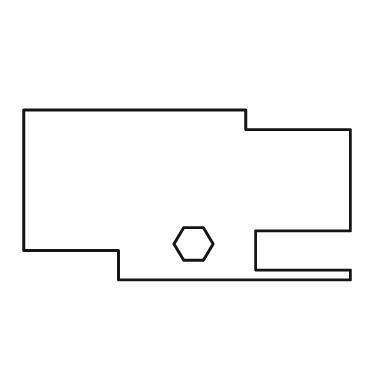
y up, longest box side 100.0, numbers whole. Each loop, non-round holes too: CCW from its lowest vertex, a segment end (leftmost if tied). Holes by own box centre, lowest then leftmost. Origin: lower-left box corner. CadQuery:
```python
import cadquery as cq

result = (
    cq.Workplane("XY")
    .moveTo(29.0, 0.0)
    .lineTo(100.0, 0.0)
    .lineTo(100.0, 3.0)
    .lineTo(71.0, 3.0)
    .lineTo(71.0, 15.0)
    .lineTo(100.0, 15.0)
    .lineTo(100.0, 46.0)
    .lineTo(68.0, 46.0)
    .lineTo(68.0, 52.0)
    .lineTo(0.0, 52.0)
    .lineTo(0.0, 9.0)
    .lineTo(29.0, 9.0)
    .close()
    .moveTo(49.0, 6.0)
    .lineTo(55.0, 6.0)
    .lineTo(58.0, 11.0)
    .lineTo(55.0, 16.0)
    .lineTo(49.0, 16.0)
    .lineTo(46.0, 11.0)
    .close()
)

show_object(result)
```